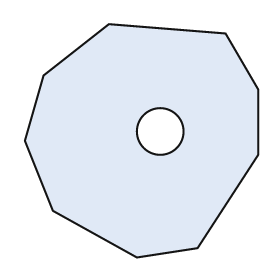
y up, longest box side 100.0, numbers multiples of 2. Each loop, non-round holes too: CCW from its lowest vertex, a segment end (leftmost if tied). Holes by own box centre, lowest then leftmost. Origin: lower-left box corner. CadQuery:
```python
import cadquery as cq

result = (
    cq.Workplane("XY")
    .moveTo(48.0, 0.0)
    .lineTo(74.0, 4.0)
    .lineTo(100.0, 44.0)
    .lineTo(100.0, 72.0)
    .lineTo(86.0, 96.0)
    .lineTo(36.0, 100.0)
    .lineTo(8.0, 78.0)
    .lineTo(0.0, 50.0)
    .lineTo(12.0, 20.0)
    .close()
    .moveTo(58.0, 54.0)
    .circle(10.0)
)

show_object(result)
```